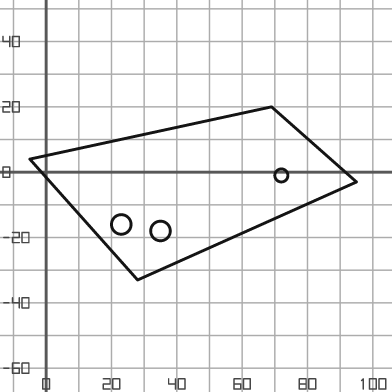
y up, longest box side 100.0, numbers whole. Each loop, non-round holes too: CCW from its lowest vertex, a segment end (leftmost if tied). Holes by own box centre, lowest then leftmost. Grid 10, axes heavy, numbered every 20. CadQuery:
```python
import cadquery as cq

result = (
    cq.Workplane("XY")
    .moveTo(28.0, -33.0)
    .lineTo(95.0, -3.0)
    .lineTo(69.0, 20.0)
    .lineTo(-5.0, 4.0)
    .close()
    .moveTo(35.0, -18.0)
    .circle(3.0)
    .moveTo(23.0, -16.0)
    .circle(3.0)
    .moveTo(72.0, -1.0)
    .circle(2.0)
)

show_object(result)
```